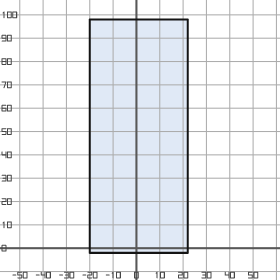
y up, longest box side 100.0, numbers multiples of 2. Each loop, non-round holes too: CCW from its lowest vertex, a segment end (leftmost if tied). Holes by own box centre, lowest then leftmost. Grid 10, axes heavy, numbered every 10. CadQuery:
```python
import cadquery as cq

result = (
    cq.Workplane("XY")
    .moveTo(-20.0, -2.0)
    .lineTo(22.0, -2.0)
    .lineTo(22.0, 98.0)
    .lineTo(-20.0, 98.0)
    .close()
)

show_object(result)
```